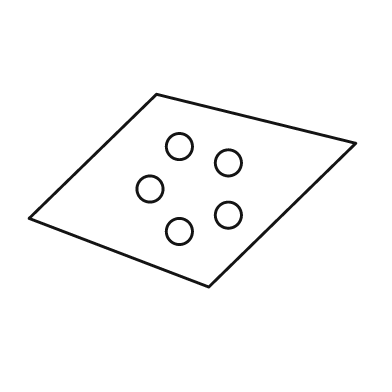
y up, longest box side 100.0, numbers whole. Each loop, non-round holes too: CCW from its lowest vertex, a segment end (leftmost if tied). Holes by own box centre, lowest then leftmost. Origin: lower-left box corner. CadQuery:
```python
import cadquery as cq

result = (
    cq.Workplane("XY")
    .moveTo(55.0, 0.0)
    .lineTo(100.0, 44.0)
    .lineTo(39.0, 59.0)
    .lineTo(0.0, 21.0)
    .close()
    .moveTo(46.0, 17.0)
    .circle(4.0)
    .moveTo(61.0, 22.0)
    .circle(4.0)
    .moveTo(37.0, 30.0)
    .circle(4.0)
    .moveTo(61.0, 38.0)
    .circle(4.0)
    .moveTo(46.0, 43.0)
    .circle(4.0)
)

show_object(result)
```